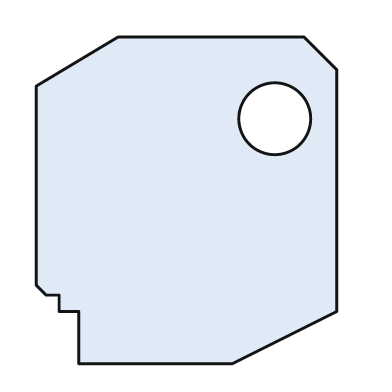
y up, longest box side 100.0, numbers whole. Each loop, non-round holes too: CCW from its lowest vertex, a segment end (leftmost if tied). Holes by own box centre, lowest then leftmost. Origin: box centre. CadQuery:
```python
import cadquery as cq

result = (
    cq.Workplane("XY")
    .moveTo(-33.0, -50.0)
    .lineTo(14.0, -50.0)
    .lineTo(46.0, -34.0)
    .lineTo(46.0, 40.0)
    .lineTo(36.0, 50.0)
    .lineTo(-21.0, 50.0)
    .lineTo(-46.0, 35.0)
    .lineTo(-46.0, -26.0)
    .lineTo(-43.0, -29.0)
    .lineTo(-39.0, -29.0)
    .lineTo(-39.0, -34.0)
    .lineTo(-33.0, -34.0)
    .close()
    .moveTo(27.0, 25.0)
    .circle(11.0)
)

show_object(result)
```